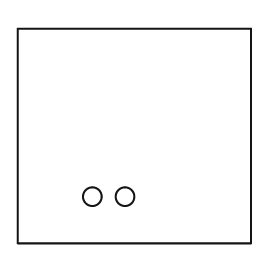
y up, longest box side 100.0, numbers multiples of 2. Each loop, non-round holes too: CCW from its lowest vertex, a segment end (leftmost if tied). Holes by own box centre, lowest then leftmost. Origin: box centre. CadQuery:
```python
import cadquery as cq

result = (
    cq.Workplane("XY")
    .moveTo(-50.0, -46.0)
    .lineTo(50.0, -46.0)
    .lineTo(50.0, 46.0)
    .lineTo(-50.0, 46.0)
    .close()
    .moveTo(-18.0, -26.0)
    .circle(4.0)
    .moveTo(-4.0, -26.0)
    .circle(4.0)
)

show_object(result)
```